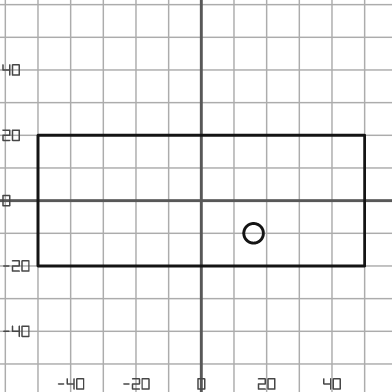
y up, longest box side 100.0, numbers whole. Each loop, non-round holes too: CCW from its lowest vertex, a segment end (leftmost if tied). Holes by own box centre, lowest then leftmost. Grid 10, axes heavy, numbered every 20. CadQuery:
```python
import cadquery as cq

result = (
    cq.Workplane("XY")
    .moveTo(-50.0, -20.0)
    .lineTo(50.0, -20.0)
    .lineTo(50.0, 20.0)
    .lineTo(-50.0, 20.0)
    .close()
    .moveTo(16.0, -10.0)
    .circle(3.0)
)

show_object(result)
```